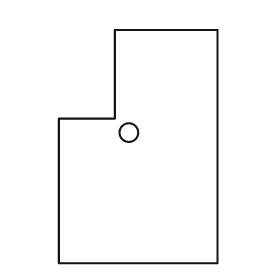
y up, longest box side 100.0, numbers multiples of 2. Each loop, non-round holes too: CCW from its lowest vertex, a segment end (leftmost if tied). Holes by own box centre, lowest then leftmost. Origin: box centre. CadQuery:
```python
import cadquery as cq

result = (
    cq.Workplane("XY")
    .moveTo(-34.0, -50.0)
    .lineTo(34.0, -50.0)
    .lineTo(34.0, 50.0)
    .lineTo(-10.0, 50.0)
    .lineTo(-10.0, 12.0)
    .lineTo(-34.0, 12.0)
    .close()
    .moveTo(-4.0, 6.0)
    .circle(4.0)
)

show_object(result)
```